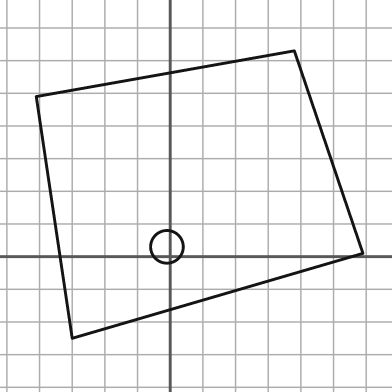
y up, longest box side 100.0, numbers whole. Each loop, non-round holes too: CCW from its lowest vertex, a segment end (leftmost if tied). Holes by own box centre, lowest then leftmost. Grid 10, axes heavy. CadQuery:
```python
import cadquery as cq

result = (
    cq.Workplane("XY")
    .moveTo(-30.0, -25.0)
    .lineTo(59.0, 1.0)
    .lineTo(38.0, 63.0)
    .lineTo(-41.0, 49.0)
    .close()
    .moveTo(-1.0, 3.0)
    .circle(5.0)
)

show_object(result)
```